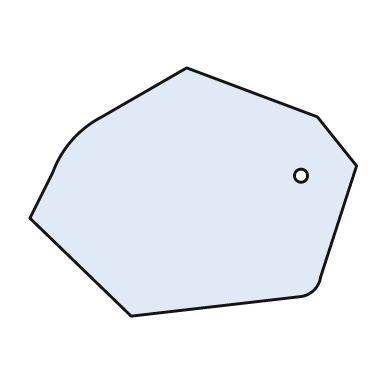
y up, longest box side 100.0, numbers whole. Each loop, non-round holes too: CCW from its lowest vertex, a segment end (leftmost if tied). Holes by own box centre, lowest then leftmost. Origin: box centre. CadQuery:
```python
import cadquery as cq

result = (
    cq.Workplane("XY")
    .moveTo(-19.0, -38.0)
    .lineTo(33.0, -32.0)
    .threePointArc((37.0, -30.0), (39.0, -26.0))
    .lineTo(50.0, 8.0)
    .lineTo(38.0, 23.0)
    .lineTo(-2.0, 38.0)
    .lineTo(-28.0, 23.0)
    .threePointArc((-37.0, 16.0), (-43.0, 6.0))
    .lineTo(-50.0, -8.0)
    .close()
    .moveTo(33.0, 5.0)
    .circle(2.0)
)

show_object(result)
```